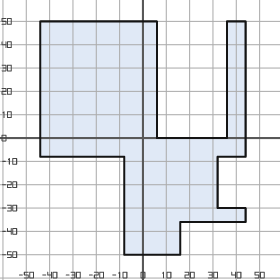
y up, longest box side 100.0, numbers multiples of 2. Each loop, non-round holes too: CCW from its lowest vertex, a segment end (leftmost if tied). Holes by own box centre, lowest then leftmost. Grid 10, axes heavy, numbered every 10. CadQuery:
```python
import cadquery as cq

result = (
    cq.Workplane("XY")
    .moveTo(-8.0, -50.0)
    .lineTo(16.0, -50.0)
    .lineTo(16.0, -36.0)
    .lineTo(44.0, -36.0)
    .lineTo(44.0, -30.0)
    .lineTo(32.0, -30.0)
    .lineTo(32.0, -8.0)
    .lineTo(44.0, -8.0)
    .lineTo(44.0, 50.0)
    .lineTo(36.0, 50.0)
    .lineTo(36.0, 0.0)
    .lineTo(6.0, 0.0)
    .lineTo(6.0, 50.0)
    .lineTo(-44.0, 50.0)
    .lineTo(-44.0, -8.0)
    .lineTo(-8.0, -8.0)
    .close()
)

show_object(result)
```